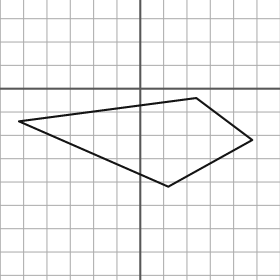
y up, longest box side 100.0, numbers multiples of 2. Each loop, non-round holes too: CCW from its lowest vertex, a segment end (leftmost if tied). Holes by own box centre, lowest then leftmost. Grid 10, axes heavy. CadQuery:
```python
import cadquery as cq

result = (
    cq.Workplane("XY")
    .moveTo(12.0, -42.0)
    .lineTo(48.0, -22.0)
    .lineTo(24.0, -4.0)
    .lineTo(-52.0, -14.0)
    .close()
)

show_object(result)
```